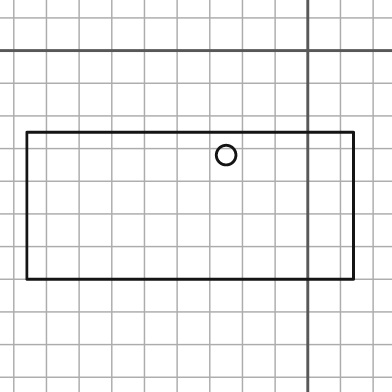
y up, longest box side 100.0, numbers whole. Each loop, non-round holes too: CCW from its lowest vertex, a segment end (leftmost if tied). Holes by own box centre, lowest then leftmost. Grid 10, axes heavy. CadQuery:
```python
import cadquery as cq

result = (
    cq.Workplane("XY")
    .moveTo(-86.0, -70.0)
    .lineTo(14.0, -70.0)
    .lineTo(14.0, -25.0)
    .lineTo(-86.0, -25.0)
    .close()
    .moveTo(-25.0, -32.0)
    .circle(3.0)
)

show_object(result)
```